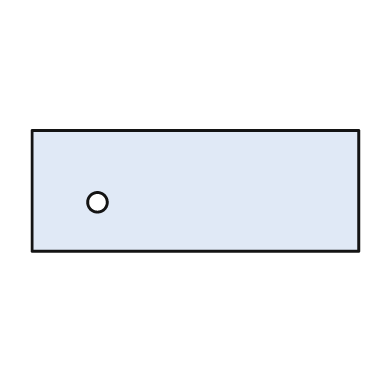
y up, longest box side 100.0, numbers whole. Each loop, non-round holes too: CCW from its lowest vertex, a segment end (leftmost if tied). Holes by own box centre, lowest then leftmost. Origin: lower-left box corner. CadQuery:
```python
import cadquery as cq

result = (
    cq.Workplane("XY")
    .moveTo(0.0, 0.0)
    .lineTo(100.0, 0.0)
    .lineTo(100.0, 37.0)
    .lineTo(0.0, 37.0)
    .close()
    .moveTo(20.0, 15.0)
    .circle(3.0)
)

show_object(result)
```